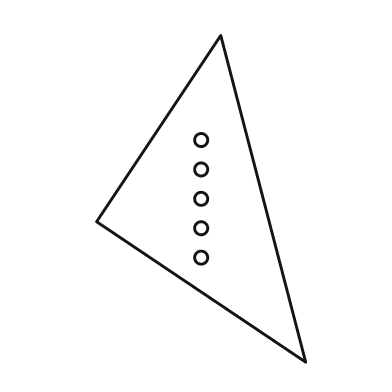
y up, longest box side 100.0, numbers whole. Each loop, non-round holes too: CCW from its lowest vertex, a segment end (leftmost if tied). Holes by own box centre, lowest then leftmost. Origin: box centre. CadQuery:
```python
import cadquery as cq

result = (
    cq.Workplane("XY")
    .moveTo(32.0, -50.0)
    .lineTo(6.0, 50.0)
    .lineTo(-32.0, -7.0)
    .close()
    .moveTo(0.0, -18.0)
    .circle(2.0)
    .moveTo(0.0, -9.0)
    .circle(2.0)
    .moveTo(0.0, 0.0)
    .circle(2.0)
    .moveTo(0.0, 9.0)
    .circle(2.0)
    .moveTo(0.0, 18.0)
    .circle(2.0)
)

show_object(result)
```